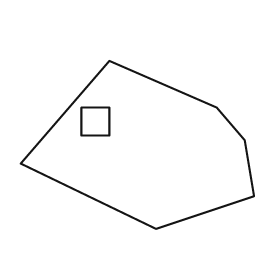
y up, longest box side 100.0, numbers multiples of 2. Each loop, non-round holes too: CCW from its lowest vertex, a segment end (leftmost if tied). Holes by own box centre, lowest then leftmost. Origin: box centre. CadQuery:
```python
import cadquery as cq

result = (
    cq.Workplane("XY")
    .moveTo(8.0, -36.0)
    .lineTo(50.0, -22.0)
    .lineTo(46.0, 2.0)
    .lineTo(34.0, 16.0)
    .lineTo(-12.0, 36.0)
    .lineTo(-50.0, -8.0)
    .close()
    .moveTo(-24.0, 4.0)
    .lineTo(-12.0, 4.0)
    .lineTo(-12.0, 16.0)
    .lineTo(-24.0, 16.0)
    .close()
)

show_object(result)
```